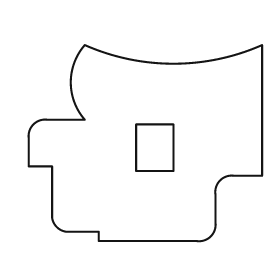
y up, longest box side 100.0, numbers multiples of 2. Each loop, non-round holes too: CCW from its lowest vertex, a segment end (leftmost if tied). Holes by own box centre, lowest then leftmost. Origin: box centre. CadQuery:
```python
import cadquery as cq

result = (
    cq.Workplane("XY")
    .moveTo(-20.0, -42.0)
    .lineTo(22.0, -42.0)
    .threePointArc((28.0, -40.0), (30.0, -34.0))
    .lineTo(30.0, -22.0)
    .threePointArc((32.0, -16.0), (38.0, -14.0))
    .lineTo(50.0, -14.0)
    .lineTo(50.0, 42.0)
    .threePointArc((12.0, 34.0), (-26.0, 42.0))
    .threePointArc((-32.0, 26.0), (-26.0, 10.0))
    .lineTo(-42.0, 10.0)
    .threePointArc((-48.0, 8.0), (-50.0, 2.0))
    .lineTo(-50.0, -10.0)
    .lineTo(-40.0, -10.0)
    .lineTo(-40.0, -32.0)
    .threePointArc((-38.0, -36.0), (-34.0, -38.0))
    .lineTo(-20.0, -38.0)
    .close()
    .moveTo(-4.0, -12.0)
    .lineTo(12.0, -12.0)
    .lineTo(12.0, 8.0)
    .lineTo(-4.0, 8.0)
    .close()
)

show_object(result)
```